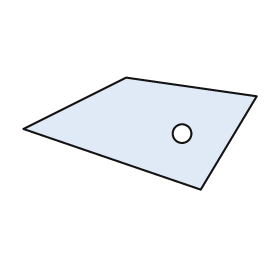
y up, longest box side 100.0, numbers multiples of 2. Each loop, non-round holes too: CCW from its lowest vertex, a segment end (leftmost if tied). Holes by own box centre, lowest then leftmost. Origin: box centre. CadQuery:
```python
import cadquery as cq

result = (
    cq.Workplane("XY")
    .moveTo(26.0, -24.0)
    .lineTo(50.0, 16.0)
    .lineTo(-6.0, 24.0)
    .lineTo(-50.0, 2.0)
    .close()
    .moveTo(18.0, 0.0)
    .circle(4.0)
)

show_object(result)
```